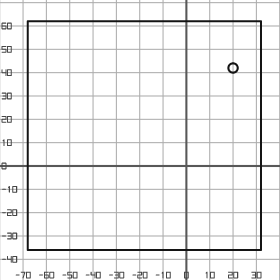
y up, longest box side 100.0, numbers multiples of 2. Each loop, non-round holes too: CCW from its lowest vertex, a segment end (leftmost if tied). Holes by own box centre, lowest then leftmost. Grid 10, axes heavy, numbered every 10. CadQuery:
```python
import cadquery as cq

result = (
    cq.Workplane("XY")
    .moveTo(-68.0, -36.0)
    .lineTo(32.0, -36.0)
    .lineTo(32.0, 62.0)
    .lineTo(-68.0, 62.0)
    .close()
    .moveTo(20.0, 42.0)
    .circle(2.0)
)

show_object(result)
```